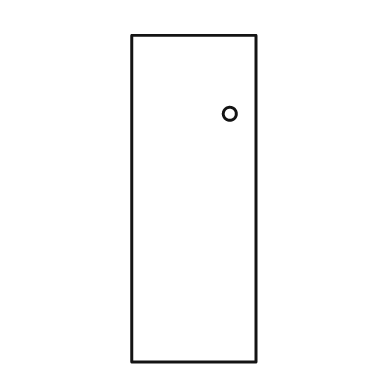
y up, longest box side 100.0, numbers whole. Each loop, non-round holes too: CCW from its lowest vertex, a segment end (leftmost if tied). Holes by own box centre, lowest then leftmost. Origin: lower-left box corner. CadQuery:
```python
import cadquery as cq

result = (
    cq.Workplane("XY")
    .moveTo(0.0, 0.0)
    .lineTo(38.0, 0.0)
    .lineTo(38.0, 100.0)
    .lineTo(0.0, 100.0)
    .close()
    .moveTo(30.0, 76.0)
    .circle(2.0)
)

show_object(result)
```